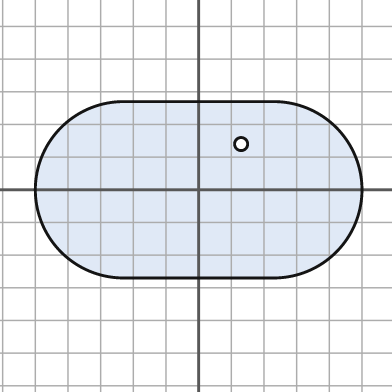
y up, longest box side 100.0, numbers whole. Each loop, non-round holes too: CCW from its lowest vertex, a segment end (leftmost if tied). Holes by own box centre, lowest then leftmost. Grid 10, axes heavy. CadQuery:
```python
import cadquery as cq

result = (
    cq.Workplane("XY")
    .moveTo(-23.0, -27.0)
    .lineTo(23.0, -27.0)
    .threePointArc((50.0, 0.0), (23.0, 27.0))
    .lineTo(-23.0, 27.0)
    .threePointArc((-50.0, 0.0), (-23.0, -27.0))
    .close()
    .moveTo(13.0, 14.0)
    .circle(2.0)
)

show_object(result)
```